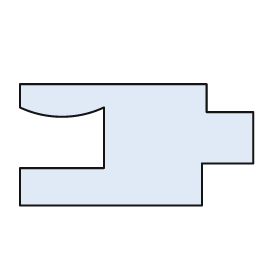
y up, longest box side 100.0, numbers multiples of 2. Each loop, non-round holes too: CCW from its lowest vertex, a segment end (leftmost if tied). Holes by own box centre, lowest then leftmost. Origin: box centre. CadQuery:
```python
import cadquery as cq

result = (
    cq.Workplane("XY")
    .moveTo(-50.0, -26.0)
    .lineTo(28.0, -26.0)
    .lineTo(28.0, -8.0)
    .lineTo(50.0, -8.0)
    .lineTo(50.0, 14.0)
    .lineTo(30.0, 14.0)
    .lineTo(30.0, 26.0)
    .lineTo(-50.0, 26.0)
    .lineTo(-50.0, 16.0)
    .threePointArc((-32.0, 12.0), (-14.0, 16.0))
    .lineTo(-14.0, -10.0)
    .lineTo(-50.0, -10.0)
    .close()
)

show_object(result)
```